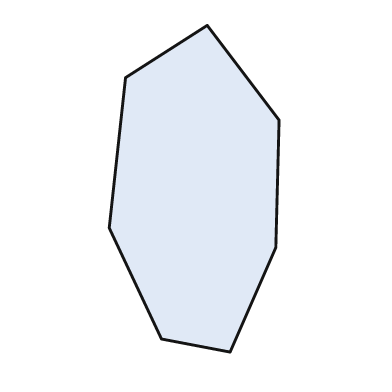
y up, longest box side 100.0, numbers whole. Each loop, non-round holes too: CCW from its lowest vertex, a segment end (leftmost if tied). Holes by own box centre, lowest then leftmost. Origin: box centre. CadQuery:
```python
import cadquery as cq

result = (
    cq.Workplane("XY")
    .moveTo(11.0, -50.0)
    .lineTo(25.0, -18.0)
    .lineTo(26.0, 21.0)
    .lineTo(4.0, 50.0)
    .lineTo(-21.0, 34.0)
    .lineTo(-26.0, -12.0)
    .lineTo(-10.0, -46.0)
    .close()
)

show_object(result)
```